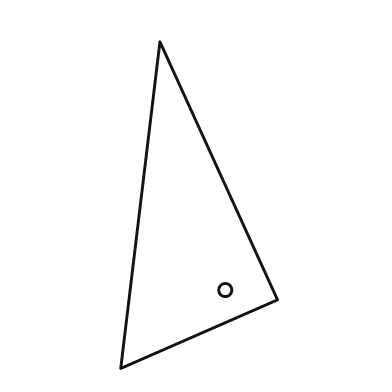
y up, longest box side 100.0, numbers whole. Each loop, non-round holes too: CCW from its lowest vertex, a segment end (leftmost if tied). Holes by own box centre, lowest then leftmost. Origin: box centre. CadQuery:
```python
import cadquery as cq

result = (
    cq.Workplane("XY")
    .moveTo(-24.0, -50.0)
    .lineTo(24.0, -29.0)
    .lineTo(-12.0, 50.0)
    .close()
    .moveTo(8.0, -26.0)
    .circle(2.0)
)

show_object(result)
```